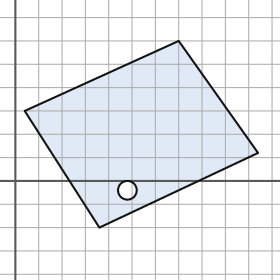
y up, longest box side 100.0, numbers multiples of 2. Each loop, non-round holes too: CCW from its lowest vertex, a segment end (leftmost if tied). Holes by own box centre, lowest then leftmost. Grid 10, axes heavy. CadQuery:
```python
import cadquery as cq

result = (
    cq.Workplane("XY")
    .moveTo(36.0, -20.0)
    .lineTo(104.0, 12.0)
    .lineTo(70.0, 60.0)
    .lineTo(4.0, 30.0)
    .close()
    .moveTo(48.0, -4.0)
    .circle(4.0)
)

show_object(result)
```